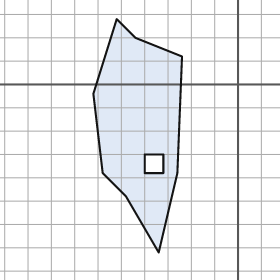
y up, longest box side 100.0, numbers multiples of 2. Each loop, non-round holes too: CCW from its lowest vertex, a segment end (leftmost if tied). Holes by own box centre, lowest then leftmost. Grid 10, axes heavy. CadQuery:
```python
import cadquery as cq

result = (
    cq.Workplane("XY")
    .moveTo(-34.0, -72.0)
    .lineTo(-26.0, -38.0)
    .lineTo(-24.0, 12.0)
    .lineTo(-44.0, 20.0)
    .lineTo(-52.0, 28.0)
    .lineTo(-62.0, -4.0)
    .lineTo(-58.0, -38.0)
    .lineTo(-48.0, -48.0)
    .close()
    .moveTo(-40.0, -38.0)
    .lineTo(-32.0, -38.0)
    .lineTo(-32.0, -30.0)
    .lineTo(-40.0, -30.0)
    .close()
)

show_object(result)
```